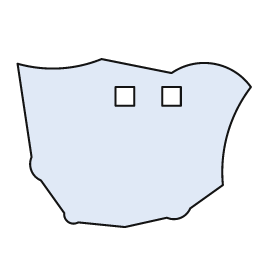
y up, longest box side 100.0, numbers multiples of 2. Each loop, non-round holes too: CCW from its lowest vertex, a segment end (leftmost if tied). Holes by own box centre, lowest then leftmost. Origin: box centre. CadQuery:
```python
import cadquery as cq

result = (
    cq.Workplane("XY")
    .moveTo(-4.0, -36.0)
    .lineTo(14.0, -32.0)
    .threePointArc((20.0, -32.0), (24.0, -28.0))
    .lineTo(38.0, -18.0)
    .threePointArc((40.0, 4.0), (50.0, 24.0))
    .threePointArc((34.0, 34.0), (16.0, 30.0))
    .lineTo(-14.0, 36.0)
    .threePointArc((-32.0, 32.0), (-50.0, 34.0))
    .lineTo(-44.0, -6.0)
    .threePointArc((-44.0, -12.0), (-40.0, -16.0))
    .lineTo(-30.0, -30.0)
    .threePointArc((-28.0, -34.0), (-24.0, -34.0))
    .close()
    .moveTo(-8.0, 16.0)
    .lineTo(0.0, 16.0)
    .lineTo(0.0, 24.0)
    .lineTo(-8.0, 24.0)
    .close()
    .moveTo(12.0, 16.0)
    .lineTo(20.0, 16.0)
    .lineTo(20.0, 24.0)
    .lineTo(12.0, 24.0)
    .close()
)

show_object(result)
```